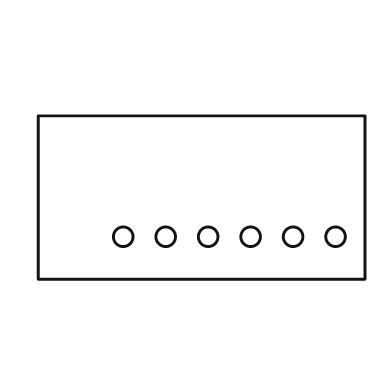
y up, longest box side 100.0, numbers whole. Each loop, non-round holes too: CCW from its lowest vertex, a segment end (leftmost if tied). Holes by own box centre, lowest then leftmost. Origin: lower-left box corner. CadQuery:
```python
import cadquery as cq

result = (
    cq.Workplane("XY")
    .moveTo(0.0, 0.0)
    .lineTo(100.0, 0.0)
    .lineTo(100.0, 50.0)
    .lineTo(0.0, 50.0)
    .close()
    .moveTo(26.0, 13.0)
    .circle(3.0)
    .moveTo(39.0, 13.0)
    .circle(3.0)
    .moveTo(52.0, 13.0)
    .circle(3.0)
    .moveTo(65.0, 13.0)
    .circle(3.0)
    .moveTo(78.0, 13.0)
    .circle(3.0)
    .moveTo(91.0, 13.0)
    .circle(3.0)
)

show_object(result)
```